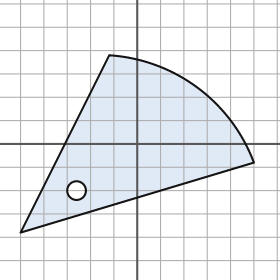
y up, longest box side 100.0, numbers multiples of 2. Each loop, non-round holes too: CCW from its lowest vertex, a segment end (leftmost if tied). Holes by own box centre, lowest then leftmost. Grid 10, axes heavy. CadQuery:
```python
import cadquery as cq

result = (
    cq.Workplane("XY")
    .moveTo(-50.0, -38.0)
    .lineTo(50.0, -8.0)
    .threePointArc((26.0, 24.0), (-12.0, 38.0))
    .close()
    .moveTo(-26.0, -20.0)
    .circle(4.0)
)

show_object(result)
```